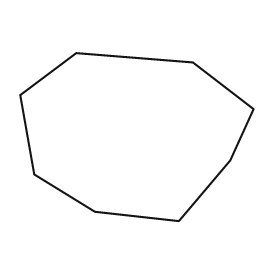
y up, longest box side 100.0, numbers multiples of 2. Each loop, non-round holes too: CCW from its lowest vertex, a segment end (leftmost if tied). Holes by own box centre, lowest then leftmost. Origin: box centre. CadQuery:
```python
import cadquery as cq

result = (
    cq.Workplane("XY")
    .moveTo(18.0, -36.0)
    .lineTo(40.0, -10.0)
    .lineTo(50.0, 12.0)
    .lineTo(24.0, 32.0)
    .lineTo(-26.0, 36.0)
    .lineTo(-50.0, 18.0)
    .lineTo(-44.0, -16.0)
    .lineTo(-18.0, -32.0)
    .close()
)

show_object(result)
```